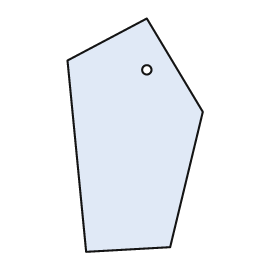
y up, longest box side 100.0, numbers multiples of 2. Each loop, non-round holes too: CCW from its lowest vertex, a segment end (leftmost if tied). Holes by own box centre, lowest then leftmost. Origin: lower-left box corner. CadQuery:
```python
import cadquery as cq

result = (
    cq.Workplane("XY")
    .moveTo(8.0, 0.0)
    .lineTo(44.0, 2.0)
    .lineTo(58.0, 60.0)
    .lineTo(34.0, 100.0)
    .lineTo(0.0, 82.0)
    .close()
    .moveTo(34.0, 78.0)
    .circle(2.0)
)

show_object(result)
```